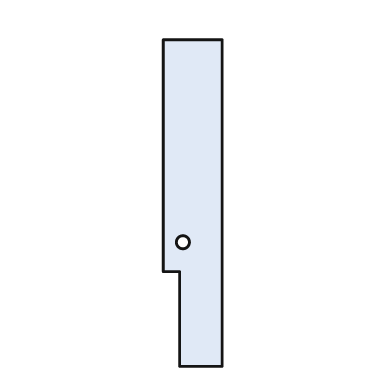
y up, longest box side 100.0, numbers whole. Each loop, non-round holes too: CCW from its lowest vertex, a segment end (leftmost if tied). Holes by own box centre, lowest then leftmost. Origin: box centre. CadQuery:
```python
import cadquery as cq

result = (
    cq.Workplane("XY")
    .moveTo(-4.0, -50.0)
    .lineTo(9.0, -50.0)
    .lineTo(9.0, 50.0)
    .lineTo(-9.0, 50.0)
    .lineTo(-9.0, -21.0)
    .lineTo(-4.0, -21.0)
    .close()
    .moveTo(-3.0, -12.0)
    .circle(2.0)
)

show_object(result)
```